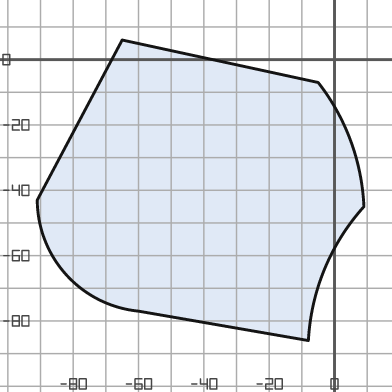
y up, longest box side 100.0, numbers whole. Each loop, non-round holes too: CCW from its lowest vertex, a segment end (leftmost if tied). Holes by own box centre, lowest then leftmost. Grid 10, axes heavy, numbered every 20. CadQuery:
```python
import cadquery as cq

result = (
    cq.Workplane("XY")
    .moveTo(-8.0, -86.0)
    .threePointArc((-3.0, -64.0), (9.0, -45.0))
    .threePointArc((5.0, -25.0), (-5.0, -7.0))
    .lineTo(-65.0, 6.0)
    .lineTo(-91.0, -43.0)
    .threePointArc((-82.0, -66.0), (-60.0, -77.0))
    .close()
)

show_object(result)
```